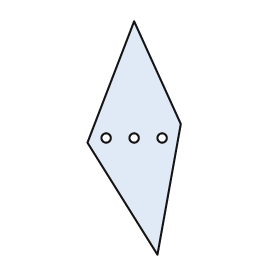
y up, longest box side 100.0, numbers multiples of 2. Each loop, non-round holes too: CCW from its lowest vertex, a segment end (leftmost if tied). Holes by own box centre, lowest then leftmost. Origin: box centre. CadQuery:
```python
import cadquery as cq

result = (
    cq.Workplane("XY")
    .moveTo(10.0, -50.0)
    .lineTo(20.0, 6.0)
    .lineTo(0.0, 50.0)
    .lineTo(-20.0, -2.0)
    .close()
    .moveTo(-12.0, 0.0)
    .circle(2.0)
    .moveTo(0.0, 0.0)
    .circle(2.0)
    .moveTo(12.0, 0.0)
    .circle(2.0)
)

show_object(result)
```